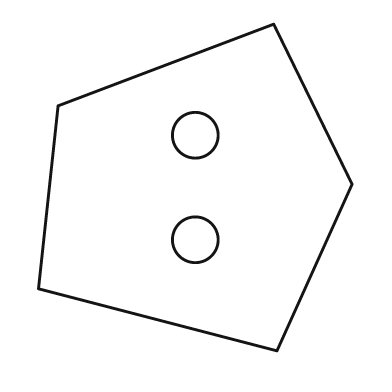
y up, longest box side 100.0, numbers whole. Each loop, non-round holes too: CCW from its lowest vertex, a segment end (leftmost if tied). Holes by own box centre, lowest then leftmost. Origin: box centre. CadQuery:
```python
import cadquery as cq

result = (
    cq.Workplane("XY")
    .moveTo(25.0, -50.0)
    .lineTo(48.0, 1.0)
    .lineTo(24.0, 50.0)
    .lineTo(-42.0, 25.0)
    .lineTo(-48.0, -31.0)
    .close()
    .moveTo(0.0, -16.0)
    .circle(7.0)
    .moveTo(0.0, 16.0)
    .circle(7.0)
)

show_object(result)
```